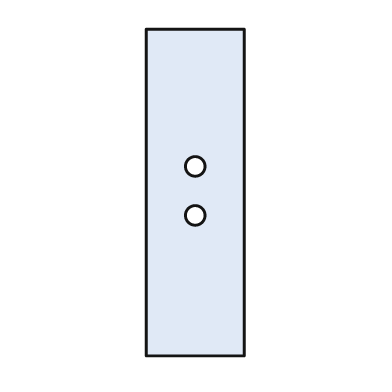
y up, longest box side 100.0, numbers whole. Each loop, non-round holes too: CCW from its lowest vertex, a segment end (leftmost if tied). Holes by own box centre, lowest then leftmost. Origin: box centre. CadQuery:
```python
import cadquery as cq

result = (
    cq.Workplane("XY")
    .moveTo(-15.0, -50.0)
    .lineTo(15.0, -50.0)
    .lineTo(15.0, 50.0)
    .lineTo(-15.0, 50.0)
    .close()
    .moveTo(0.0, -7.0)
    .circle(3.0)
    .moveTo(0.0, 8.0)
    .circle(3.0)
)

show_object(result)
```